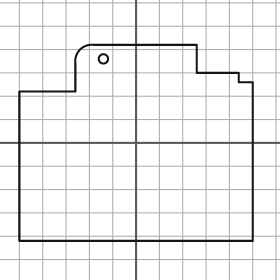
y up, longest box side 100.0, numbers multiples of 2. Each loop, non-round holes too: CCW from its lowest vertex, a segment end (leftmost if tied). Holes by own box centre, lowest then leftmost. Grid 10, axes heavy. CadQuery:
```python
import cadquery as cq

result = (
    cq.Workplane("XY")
    .moveTo(-50.0, -42.0)
    .lineTo(50.0, -42.0)
    .lineTo(50.0, 26.0)
    .lineTo(44.0, 26.0)
    .lineTo(44.0, 30.0)
    .lineTo(26.0, 30.0)
    .lineTo(26.0, 42.0)
    .lineTo(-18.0, 42.0)
    .threePointArc((-24.0, 40.0), (-26.0, 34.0))
    .lineTo(-26.0, 22.0)
    .lineTo(-50.0, 22.0)
    .close()
    .moveTo(-14.0, 36.0)
    .circle(2.0)
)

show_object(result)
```